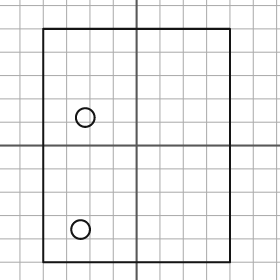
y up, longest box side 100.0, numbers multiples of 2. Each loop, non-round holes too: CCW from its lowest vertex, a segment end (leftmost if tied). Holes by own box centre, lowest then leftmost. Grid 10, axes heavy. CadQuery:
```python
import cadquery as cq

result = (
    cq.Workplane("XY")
    .moveTo(-40.0, -50.0)
    .lineTo(40.0, -50.0)
    .lineTo(40.0, 50.0)
    .lineTo(-40.0, 50.0)
    .close()
    .moveTo(-24.0, -36.0)
    .circle(4.0)
    .moveTo(-22.0, 12.0)
    .circle(4.0)
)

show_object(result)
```